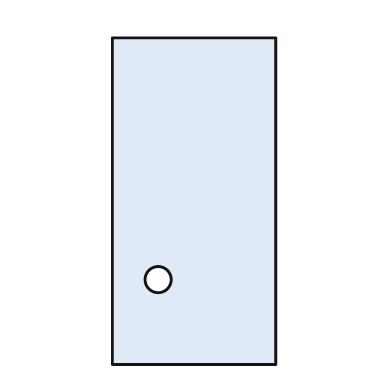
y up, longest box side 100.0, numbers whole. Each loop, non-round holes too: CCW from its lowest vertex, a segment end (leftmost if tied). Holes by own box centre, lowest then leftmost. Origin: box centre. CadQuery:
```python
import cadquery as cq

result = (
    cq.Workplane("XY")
    .moveTo(-25.0, -50.0)
    .lineTo(25.0, -50.0)
    .lineTo(25.0, 50.0)
    .lineTo(-25.0, 50.0)
    .close()
    .moveTo(-11.0, -24.0)
    .circle(4.0)
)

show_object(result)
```